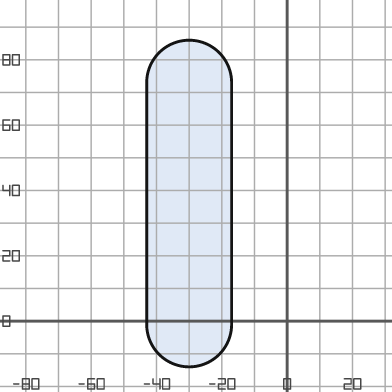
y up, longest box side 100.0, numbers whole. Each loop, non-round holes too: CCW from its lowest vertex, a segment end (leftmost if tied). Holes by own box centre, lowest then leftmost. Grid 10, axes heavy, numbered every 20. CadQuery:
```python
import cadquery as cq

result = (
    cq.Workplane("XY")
    .moveTo(-43.0, -1.0)
    .threePointArc((-30.0, -14.0), (-17.0, -1.0))
    .lineTo(-17.0, 73.0)
    .threePointArc((-30.0, 86.0), (-43.0, 73.0))
    .close()
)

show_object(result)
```